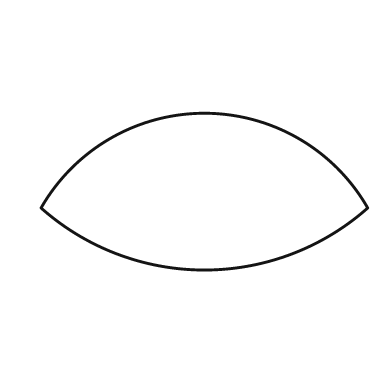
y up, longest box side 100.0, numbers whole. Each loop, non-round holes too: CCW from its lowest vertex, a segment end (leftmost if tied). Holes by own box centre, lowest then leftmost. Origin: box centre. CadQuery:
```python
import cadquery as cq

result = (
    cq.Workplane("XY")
    .moveTo(-50.0, -5.0)
    .threePointArc((0.0, -24.0), (50.0, -5.0))
    .threePointArc((0.0, 24.0), (-50.0, -5.0))
    .close()
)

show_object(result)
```